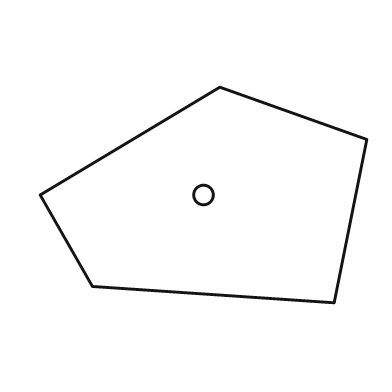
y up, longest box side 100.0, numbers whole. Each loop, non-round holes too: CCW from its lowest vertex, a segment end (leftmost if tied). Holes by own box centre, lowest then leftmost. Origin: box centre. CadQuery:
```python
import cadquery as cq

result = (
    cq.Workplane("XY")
    .moveTo(40.0, -33.0)
    .lineTo(50.0, 17.0)
    .lineTo(5.0, 33.0)
    .lineTo(-50.0, 0.0)
    .lineTo(-34.0, -28.0)
    .close()
    .moveTo(0.0, 0.0)
    .circle(3.0)
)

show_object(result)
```